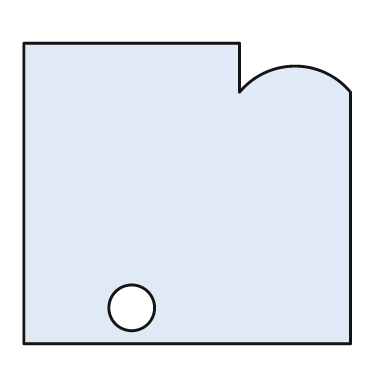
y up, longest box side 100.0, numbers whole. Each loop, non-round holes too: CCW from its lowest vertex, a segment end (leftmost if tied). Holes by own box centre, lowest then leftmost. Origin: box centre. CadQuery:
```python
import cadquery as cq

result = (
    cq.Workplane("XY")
    .moveTo(-50.0, -46.0)
    .lineTo(50.0, -46.0)
    .lineTo(50.0, 31.0)
    .threePointArc((33.0, 39.0), (16.0, 31.0))
    .lineTo(16.0, 46.0)
    .lineTo(-50.0, 46.0)
    .close()
    .moveTo(-17.0, -35.0)
    .circle(7.0)
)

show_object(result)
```